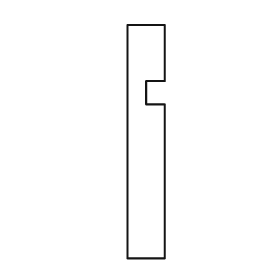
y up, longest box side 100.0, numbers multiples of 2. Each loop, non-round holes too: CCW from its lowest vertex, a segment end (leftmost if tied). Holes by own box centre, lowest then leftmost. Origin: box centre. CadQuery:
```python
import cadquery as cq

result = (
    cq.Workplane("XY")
    .moveTo(-8.0, -50.0)
    .lineTo(8.0, -50.0)
    .lineTo(8.0, 16.0)
    .lineTo(0.0, 16.0)
    .lineTo(0.0, 26.0)
    .lineTo(8.0, 26.0)
    .lineTo(8.0, 50.0)
    .lineTo(-8.0, 50.0)
    .close()
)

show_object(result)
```